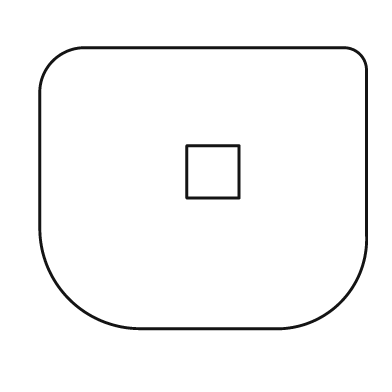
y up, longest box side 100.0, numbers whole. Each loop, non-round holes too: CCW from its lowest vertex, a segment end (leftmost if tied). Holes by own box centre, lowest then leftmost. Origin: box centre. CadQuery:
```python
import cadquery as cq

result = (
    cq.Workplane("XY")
    .moveTo(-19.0, -43.0)
    .lineTo(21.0, -43.0)
    .threePointArc((42.0, -35.0), (50.0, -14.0))
    .lineTo(50.0, 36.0)
    .threePointArc((48.0, 41.0), (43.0, 43.0))
    .lineTo(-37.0, 43.0)
    .threePointArc((-46.0, 39.0), (-50.0, 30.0))
    .lineTo(-50.0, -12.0)
    .threePointArc((-41.0, -34.0), (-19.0, -43.0))
    .close()
    .moveTo(-5.0, -3.0)
    .lineTo(11.0, -3.0)
    .lineTo(11.0, 13.0)
    .lineTo(-5.0, 13.0)
    .close()
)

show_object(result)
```